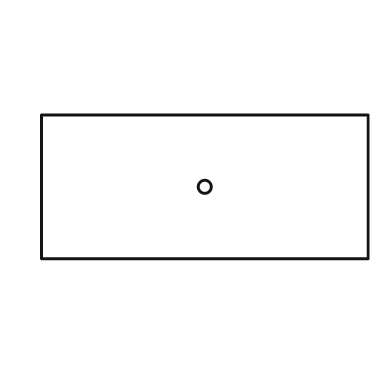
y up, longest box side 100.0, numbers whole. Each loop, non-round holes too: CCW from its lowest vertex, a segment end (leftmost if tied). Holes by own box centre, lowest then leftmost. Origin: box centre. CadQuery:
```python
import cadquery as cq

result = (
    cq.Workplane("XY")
    .moveTo(-50.0, -22.0)
    .lineTo(50.0, -22.0)
    .lineTo(50.0, 22.0)
    .lineTo(-50.0, 22.0)
    .close()
    .moveTo(0.0, 0.0)
    .circle(2.0)
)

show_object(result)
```